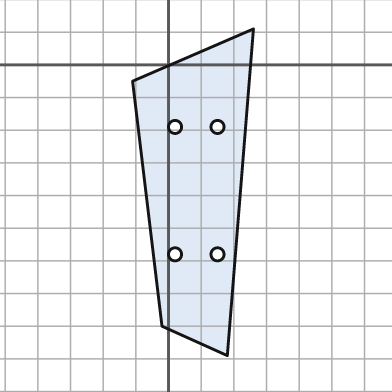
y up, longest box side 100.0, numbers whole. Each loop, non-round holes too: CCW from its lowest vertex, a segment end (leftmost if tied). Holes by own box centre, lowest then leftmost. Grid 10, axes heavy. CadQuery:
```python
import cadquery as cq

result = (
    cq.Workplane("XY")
    .moveTo(18.0, -89.0)
    .lineTo(26.0, 11.0)
    .lineTo(-11.0, -5.0)
    .lineTo(-2.0, -80.0)
    .close()
    .moveTo(2.0, -58.0)
    .circle(2.0)
    .moveTo(15.0, -58.0)
    .circle(2.0)
    .moveTo(2.0, -19.0)
    .circle(2.0)
    .moveTo(15.0, -19.0)
    .circle(2.0)
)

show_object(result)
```